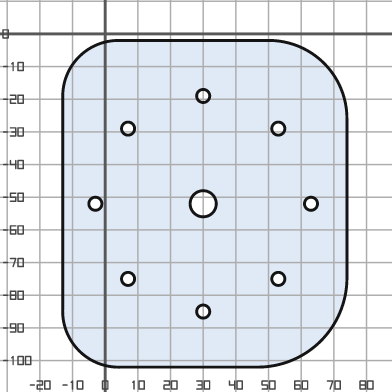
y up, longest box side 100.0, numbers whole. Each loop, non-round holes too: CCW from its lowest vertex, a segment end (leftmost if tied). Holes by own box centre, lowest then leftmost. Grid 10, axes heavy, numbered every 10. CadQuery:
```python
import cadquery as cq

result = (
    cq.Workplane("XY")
    .moveTo(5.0, -102.0)
    .lineTo(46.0, -102.0)
    .threePointArc((66.0, -94.0), (74.0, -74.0))
    .lineTo(74.0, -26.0)
    .threePointArc((67.0, -9.0), (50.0, -2.0))
    .lineTo(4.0, -2.0)
    .threePointArc((-8.0, -7.0), (-13.0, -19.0))
    .lineTo(-13.0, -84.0)
    .threePointArc((-8.0, -97.0), (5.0, -102.0))
    .close()
    .moveTo(30.0, -85.0)
    .circle(2.0)
    .moveTo(7.0, -75.0)
    .circle(2.0)
    .moveTo(53.0, -75.0)
    .circle(2.0)
    .moveTo(-3.0, -52.0)
    .circle(2.0)
    .moveTo(30.0, -52.0)
    .circle(4.0)
    .moveTo(63.0, -52.0)
    .circle(2.0)
    .moveTo(7.0, -29.0)
    .circle(2.0)
    .moveTo(53.0, -29.0)
    .circle(2.0)
    .moveTo(30.0, -19.0)
    .circle(2.0)
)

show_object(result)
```